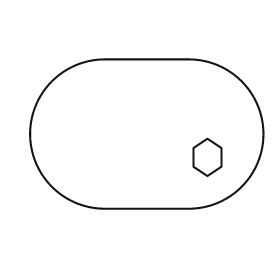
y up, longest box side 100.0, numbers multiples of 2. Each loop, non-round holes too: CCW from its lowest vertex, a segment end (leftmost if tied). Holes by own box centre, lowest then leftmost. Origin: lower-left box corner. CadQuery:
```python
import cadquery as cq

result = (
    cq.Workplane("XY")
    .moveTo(32.0, 0.0)
    .lineTo(68.0, 0.0)
    .threePointArc((100.0, 32.0), (68.0, 64.0))
    .lineTo(32.0, 64.0)
    .threePointArc((0.0, 32.0), (32.0, 0.0))
    .close()
    .moveTo(76.0, 14.0)
    .lineTo(82.0, 18.0)
    .lineTo(82.0, 26.0)
    .lineTo(76.0, 30.0)
    .lineTo(70.0, 26.0)
    .lineTo(70.0, 18.0)
    .close()
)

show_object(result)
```